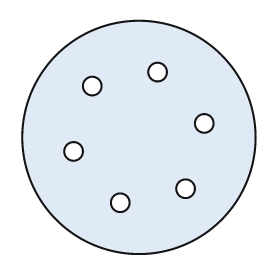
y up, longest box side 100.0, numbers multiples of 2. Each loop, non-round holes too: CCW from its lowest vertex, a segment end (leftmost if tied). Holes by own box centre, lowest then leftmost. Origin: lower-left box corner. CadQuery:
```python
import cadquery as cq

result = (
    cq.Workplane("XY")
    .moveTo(50.0, 50.0)
    .circle(50.0)
    .moveTo(42.0, 22.0)
    .circle(4.0)
    .moveTo(70.0, 28.0)
    .circle(4.0)
    .moveTo(22.0, 44.0)
    .circle(4.0)
    .moveTo(78.0, 56.0)
    .circle(4.0)
    .moveTo(30.0, 72.0)
    .circle(4.0)
    .moveTo(58.0, 78.0)
    .circle(4.0)
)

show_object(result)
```